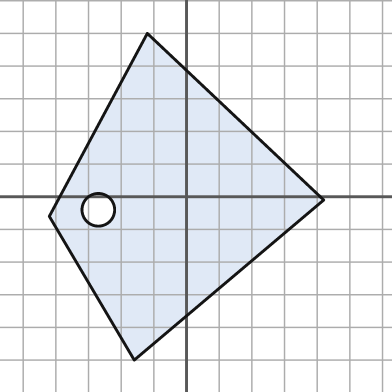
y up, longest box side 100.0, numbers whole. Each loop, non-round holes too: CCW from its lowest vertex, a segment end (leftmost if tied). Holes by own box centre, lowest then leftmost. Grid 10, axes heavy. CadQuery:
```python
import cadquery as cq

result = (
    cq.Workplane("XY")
    .moveTo(-16.0, -50.0)
    .lineTo(42.0, -1.0)
    .lineTo(-12.0, 50.0)
    .lineTo(-42.0, -6.0)
    .close()
    .moveTo(-27.0, -4.0)
    .circle(5.0)
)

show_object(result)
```